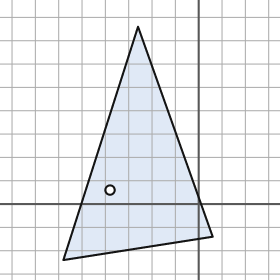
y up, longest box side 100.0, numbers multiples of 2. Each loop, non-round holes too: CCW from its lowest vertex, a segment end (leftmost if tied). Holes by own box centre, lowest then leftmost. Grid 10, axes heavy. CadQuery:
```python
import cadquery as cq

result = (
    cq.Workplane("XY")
    .moveTo(-58.0, -24.0)
    .lineTo(6.0, -14.0)
    .lineTo(-26.0, 76.0)
    .close()
    .moveTo(-38.0, 6.0)
    .circle(2.0)
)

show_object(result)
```